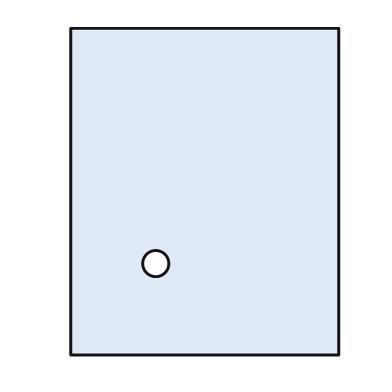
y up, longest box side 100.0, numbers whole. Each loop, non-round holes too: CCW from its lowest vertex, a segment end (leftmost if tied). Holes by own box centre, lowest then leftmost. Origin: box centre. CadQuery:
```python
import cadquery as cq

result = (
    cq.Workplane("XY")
    .moveTo(-41.0, -50.0)
    .lineTo(41.0, -50.0)
    .lineTo(41.0, 50.0)
    .lineTo(-41.0, 50.0)
    .close()
    .moveTo(-15.0, -22.0)
    .circle(4.0)
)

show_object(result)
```